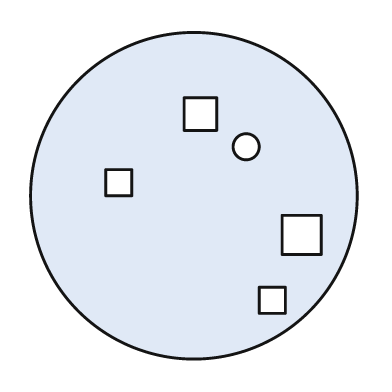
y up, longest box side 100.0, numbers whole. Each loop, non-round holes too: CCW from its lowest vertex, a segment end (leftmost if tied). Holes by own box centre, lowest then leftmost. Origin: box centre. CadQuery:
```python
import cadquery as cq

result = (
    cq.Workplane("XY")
    .moveTo(0.0, 0.0)
    .circle(50.0)
    .moveTo(20.0, -36.0)
    .lineTo(28.0, -36.0)
    .lineTo(28.0, -28.0)
    .lineTo(20.0, -28.0)
    .close()
    .moveTo(27.0, -18.0)
    .lineTo(39.0, -18.0)
    .lineTo(39.0, -6.0)
    .lineTo(27.0, -6.0)
    .close()
    .moveTo(-27.0, 0.0)
    .lineTo(-19.0, 0.0)
    .lineTo(-19.0, 8.0)
    .lineTo(-27.0, 8.0)
    .close()
    .moveTo(16.0, 15.0)
    .circle(4.0)
    .moveTo(-3.0, 20.0)
    .lineTo(7.0, 20.0)
    .lineTo(7.0, 30.0)
    .lineTo(-3.0, 30.0)
    .close()
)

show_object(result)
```